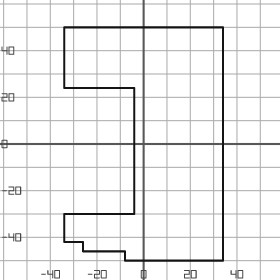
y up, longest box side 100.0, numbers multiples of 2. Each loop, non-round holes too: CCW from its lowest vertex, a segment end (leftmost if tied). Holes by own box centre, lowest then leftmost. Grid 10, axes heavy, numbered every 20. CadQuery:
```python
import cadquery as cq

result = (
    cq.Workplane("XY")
    .moveTo(-8.0, -50.0)
    .lineTo(34.0, -50.0)
    .lineTo(34.0, 50.0)
    .lineTo(-34.0, 50.0)
    .lineTo(-34.0, 24.0)
    .lineTo(-4.0, 24.0)
    .lineTo(-4.0, -30.0)
    .lineTo(-34.0, -30.0)
    .lineTo(-34.0, -42.0)
    .lineTo(-26.0, -42.0)
    .lineTo(-26.0, -46.0)
    .lineTo(-8.0, -46.0)
    .close()
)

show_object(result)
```